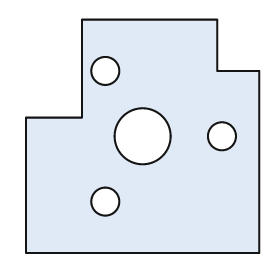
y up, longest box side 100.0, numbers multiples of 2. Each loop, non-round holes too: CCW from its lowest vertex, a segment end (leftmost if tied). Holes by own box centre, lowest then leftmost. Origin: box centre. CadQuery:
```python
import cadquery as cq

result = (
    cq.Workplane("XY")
    .moveTo(-50.0, -50.0)
    .lineTo(50.0, -50.0)
    .lineTo(50.0, 28.0)
    .lineTo(32.0, 28.0)
    .lineTo(32.0, 50.0)
    .lineTo(-26.0, 50.0)
    .lineTo(-26.0, 8.0)
    .lineTo(-50.0, 8.0)
    .close()
    .moveTo(-16.0, -28.0)
    .circle(6.0)
    .moveTo(0.0, 0.0)
    .circle(12.0)
    .moveTo(34.0, 0.0)
    .circle(6.0)
    .moveTo(-16.0, 28.0)
    .circle(6.0)
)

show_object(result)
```